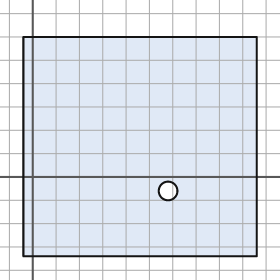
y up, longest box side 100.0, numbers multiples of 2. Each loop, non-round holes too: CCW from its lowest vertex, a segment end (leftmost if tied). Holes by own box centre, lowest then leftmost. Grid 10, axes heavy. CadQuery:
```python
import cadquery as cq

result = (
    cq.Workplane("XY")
    .moveTo(-4.0, -34.0)
    .lineTo(96.0, -34.0)
    .lineTo(96.0, 60.0)
    .lineTo(-4.0, 60.0)
    .close()
    .moveTo(58.0, -6.0)
    .circle(4.0)
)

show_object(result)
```